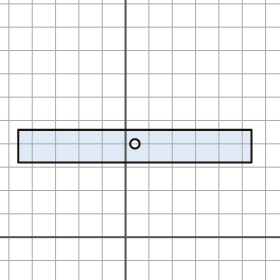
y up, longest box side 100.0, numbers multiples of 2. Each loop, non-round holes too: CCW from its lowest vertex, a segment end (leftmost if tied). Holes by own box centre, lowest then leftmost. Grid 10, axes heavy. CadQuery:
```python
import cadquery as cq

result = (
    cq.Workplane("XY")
    .moveTo(-46.0, 32.0)
    .lineTo(54.0, 32.0)
    .lineTo(54.0, 46.0)
    .lineTo(-46.0, 46.0)
    .close()
    .moveTo(4.0, 40.0)
    .circle(2.0)
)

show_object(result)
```